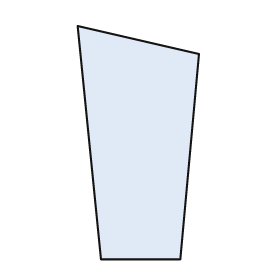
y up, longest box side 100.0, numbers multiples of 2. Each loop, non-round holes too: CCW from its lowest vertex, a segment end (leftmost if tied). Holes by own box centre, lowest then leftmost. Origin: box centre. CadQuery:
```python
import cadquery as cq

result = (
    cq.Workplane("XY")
    .moveTo(-16.0, -50.0)
    .lineTo(18.0, -50.0)
    .lineTo(26.0, 38.0)
    .lineTo(-26.0, 50.0)
    .close()
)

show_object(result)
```